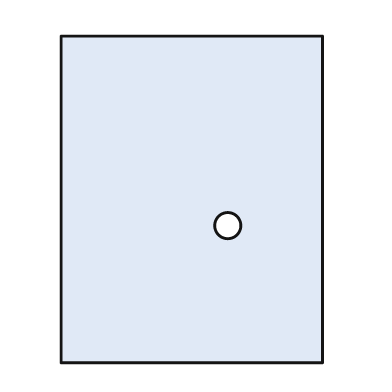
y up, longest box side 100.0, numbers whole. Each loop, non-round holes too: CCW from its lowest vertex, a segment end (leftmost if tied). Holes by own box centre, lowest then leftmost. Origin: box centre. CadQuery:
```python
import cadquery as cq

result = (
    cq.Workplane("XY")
    .moveTo(-40.0, -50.0)
    .lineTo(40.0, -50.0)
    .lineTo(40.0, 50.0)
    .lineTo(-40.0, 50.0)
    .close()
    .moveTo(11.0, -8.0)
    .circle(4.0)
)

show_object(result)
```